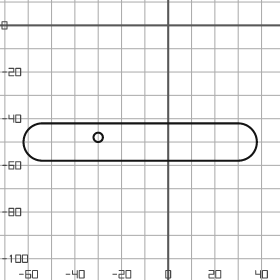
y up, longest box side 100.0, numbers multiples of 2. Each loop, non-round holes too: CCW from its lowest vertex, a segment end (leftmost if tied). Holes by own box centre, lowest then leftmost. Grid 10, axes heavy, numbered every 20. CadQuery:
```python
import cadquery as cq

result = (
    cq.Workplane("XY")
    .moveTo(-54.0, -58.0)
    .lineTo(30.0, -58.0)
    .threePointArc((38.0, -50.0), (30.0, -42.0))
    .lineTo(-54.0, -42.0)
    .threePointArc((-62.0, -50.0), (-54.0, -58.0))
    .close()
    .moveTo(-30.0, -48.0)
    .circle(2.0)
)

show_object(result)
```